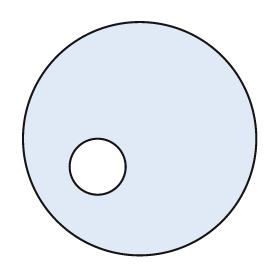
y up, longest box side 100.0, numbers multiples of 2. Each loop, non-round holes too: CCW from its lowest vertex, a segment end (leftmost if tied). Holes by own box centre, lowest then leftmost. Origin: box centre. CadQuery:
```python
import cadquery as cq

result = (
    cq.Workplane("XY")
    .moveTo(0.0, 0.0)
    .circle(50.0)
    .moveTo(-18.0, -12.0)
    .circle(12.0)
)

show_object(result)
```